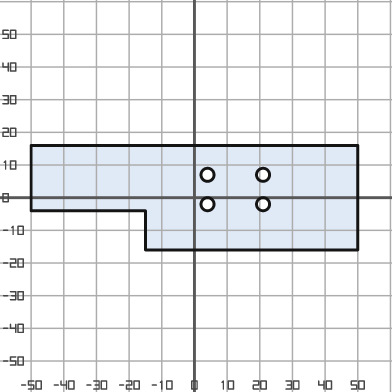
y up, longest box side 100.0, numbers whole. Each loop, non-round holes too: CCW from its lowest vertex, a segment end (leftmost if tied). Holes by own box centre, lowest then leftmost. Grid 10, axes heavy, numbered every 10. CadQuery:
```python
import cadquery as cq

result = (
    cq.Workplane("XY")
    .moveTo(-15.0, -16.0)
    .lineTo(50.0, -16.0)
    .lineTo(50.0, 16.0)
    .lineTo(-50.0, 16.0)
    .lineTo(-50.0, -4.0)
    .lineTo(-15.0, -4.0)
    .close()
    .moveTo(4.0, -2.0)
    .circle(2.0)
    .moveTo(21.0, -2.0)
    .circle(2.0)
    .moveTo(4.0, 7.0)
    .circle(2.0)
    .moveTo(21.0, 7.0)
    .circle(2.0)
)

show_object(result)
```